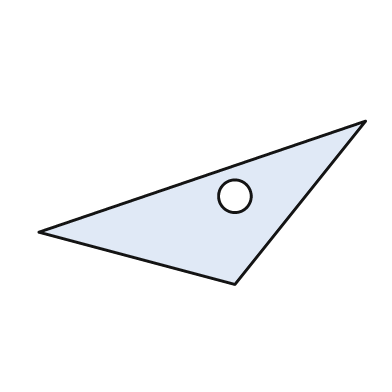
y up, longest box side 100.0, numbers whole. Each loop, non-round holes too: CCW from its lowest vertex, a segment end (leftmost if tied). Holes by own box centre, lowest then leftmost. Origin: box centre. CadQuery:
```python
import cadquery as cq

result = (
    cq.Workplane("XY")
    .moveTo(10.0, -25.0)
    .lineTo(50.0, 25.0)
    .lineTo(-50.0, -9.0)
    .close()
    .moveTo(10.0, 2.0)
    .circle(5.0)
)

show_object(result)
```